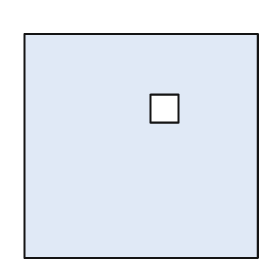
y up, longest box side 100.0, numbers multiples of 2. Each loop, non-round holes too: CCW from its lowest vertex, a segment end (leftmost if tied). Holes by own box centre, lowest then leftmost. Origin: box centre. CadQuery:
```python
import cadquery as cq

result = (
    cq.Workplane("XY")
    .moveTo(-50.0, -48.0)
    .lineTo(50.0, -48.0)
    .lineTo(50.0, 48.0)
    .lineTo(-50.0, 48.0)
    .close()
    .moveTo(4.0, 10.0)
    .lineTo(16.0, 10.0)
    .lineTo(16.0, 22.0)
    .lineTo(4.0, 22.0)
    .close()
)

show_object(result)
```